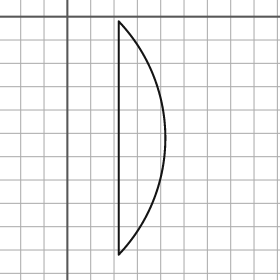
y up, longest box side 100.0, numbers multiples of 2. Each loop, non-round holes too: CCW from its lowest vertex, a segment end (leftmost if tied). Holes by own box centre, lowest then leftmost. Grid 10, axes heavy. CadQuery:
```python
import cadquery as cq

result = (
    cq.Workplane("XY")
    .moveTo(22.0, -102.0)
    .threePointArc((42.0, -52.0), (22.0, -2.0))
    .close()
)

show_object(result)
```